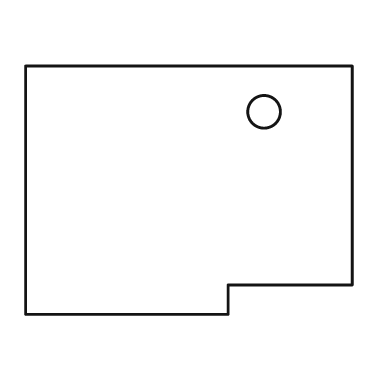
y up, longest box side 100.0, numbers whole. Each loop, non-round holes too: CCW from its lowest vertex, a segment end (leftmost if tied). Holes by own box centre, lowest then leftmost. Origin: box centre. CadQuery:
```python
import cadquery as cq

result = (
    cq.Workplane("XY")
    .moveTo(-50.0, -38.0)
    .lineTo(12.0, -38.0)
    .lineTo(12.0, -29.0)
    .lineTo(50.0, -29.0)
    .lineTo(50.0, 38.0)
    .lineTo(-50.0, 38.0)
    .close()
    .moveTo(23.0, 24.0)
    .circle(5.0)
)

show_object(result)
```